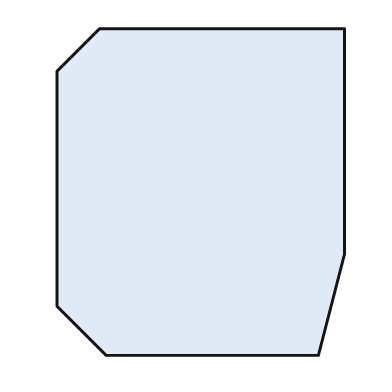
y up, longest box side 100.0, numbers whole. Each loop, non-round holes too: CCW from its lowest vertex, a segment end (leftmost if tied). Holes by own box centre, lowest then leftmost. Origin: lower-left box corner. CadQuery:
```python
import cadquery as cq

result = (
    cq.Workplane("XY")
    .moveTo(15.0, 0.0)
    .lineTo(80.0, 0.0)
    .lineTo(88.0, 31.0)
    .lineTo(88.0, 100.0)
    .lineTo(13.0, 100.0)
    .lineTo(0.0, 87.0)
    .lineTo(0.0, 15.0)
    .close()
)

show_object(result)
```